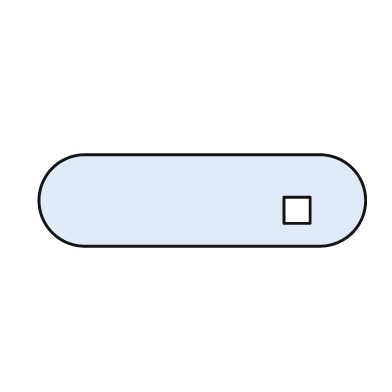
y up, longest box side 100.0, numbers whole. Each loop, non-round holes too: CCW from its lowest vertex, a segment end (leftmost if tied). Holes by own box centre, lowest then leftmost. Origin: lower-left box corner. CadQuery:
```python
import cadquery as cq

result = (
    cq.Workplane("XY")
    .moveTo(14.0, 0.0)
    .lineTo(86.0, 0.0)
    .threePointArc((100.0, 14.0), (86.0, 28.0))
    .lineTo(14.0, 28.0)
    .threePointArc((0.0, 14.0), (14.0, 0.0))
    .close()
    .moveTo(75.0, 7.0)
    .lineTo(83.0, 7.0)
    .lineTo(83.0, 15.0)
    .lineTo(75.0, 15.0)
    .close()
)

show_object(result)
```